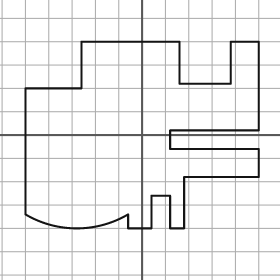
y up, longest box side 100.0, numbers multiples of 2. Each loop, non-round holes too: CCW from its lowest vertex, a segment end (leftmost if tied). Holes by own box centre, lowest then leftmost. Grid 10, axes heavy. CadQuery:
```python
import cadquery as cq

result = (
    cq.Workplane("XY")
    .moveTo(-6.0, -40.0)
    .lineTo(4.0, -40.0)
    .lineTo(4.0, -26.0)
    .lineTo(12.0, -26.0)
    .lineTo(12.0, -40.0)
    .lineTo(18.0, -40.0)
    .lineTo(18.0, -18.0)
    .lineTo(50.0, -18.0)
    .lineTo(50.0, -6.0)
    .lineTo(12.0, -6.0)
    .lineTo(12.0, 2.0)
    .lineTo(50.0, 2.0)
    .lineTo(50.0, 40.0)
    .lineTo(38.0, 40.0)
    .lineTo(38.0, 22.0)
    .lineTo(16.0, 22.0)
    .lineTo(16.0, 40.0)
    .lineTo(-26.0, 40.0)
    .lineTo(-26.0, 20.0)
    .lineTo(-50.0, 20.0)
    .lineTo(-50.0, -34.0)
    .threePointArc((-28.0, -40.0), (-6.0, -34.0))
    .close()
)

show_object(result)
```